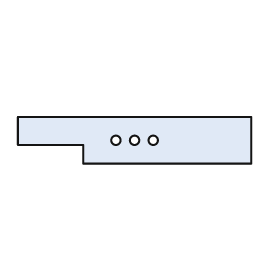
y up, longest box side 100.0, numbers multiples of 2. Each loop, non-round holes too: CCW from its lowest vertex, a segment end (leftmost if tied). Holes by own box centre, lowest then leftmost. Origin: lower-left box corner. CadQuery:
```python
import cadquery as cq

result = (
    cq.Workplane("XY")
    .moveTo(28.0, 0.0)
    .lineTo(100.0, 0.0)
    .lineTo(100.0, 20.0)
    .lineTo(0.0, 20.0)
    .lineTo(0.0, 8.0)
    .lineTo(28.0, 8.0)
    .close()
    .moveTo(42.0, 10.0)
    .circle(2.0)
    .moveTo(50.0, 10.0)
    .circle(2.0)
    .moveTo(58.0, 10.0)
    .circle(2.0)
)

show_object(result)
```